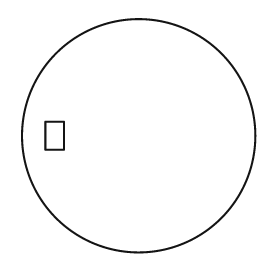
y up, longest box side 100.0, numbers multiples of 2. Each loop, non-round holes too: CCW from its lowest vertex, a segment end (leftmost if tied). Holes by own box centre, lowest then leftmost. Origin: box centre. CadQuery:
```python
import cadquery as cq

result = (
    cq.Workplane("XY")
    .moveTo(0.0, 0.0)
    .circle(50.0)
    .moveTo(-40.0, -6.0)
    .lineTo(-32.0, -6.0)
    .lineTo(-32.0, 6.0)
    .lineTo(-40.0, 6.0)
    .close()
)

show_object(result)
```